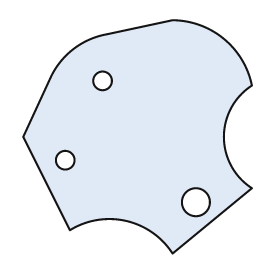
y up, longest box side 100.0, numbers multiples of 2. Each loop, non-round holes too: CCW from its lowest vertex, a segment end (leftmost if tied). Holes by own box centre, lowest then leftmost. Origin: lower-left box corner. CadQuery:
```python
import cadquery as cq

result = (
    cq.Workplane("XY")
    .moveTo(64.0, 0.0)
    .lineTo(98.0, 28.0)
    .threePointArc((86.0, 50.0), (98.0, 72.0))
    .threePointArc((86.0, 92.0), (64.0, 100.0))
    .lineTo(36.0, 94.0)
    .threePointArc((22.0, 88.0), (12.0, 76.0))
    .lineTo(0.0, 50.0)
    .lineTo(20.0, 10.0)
    .threePointArc((44.0, 14.0), (64.0, 0.0))
    .close()
    .moveTo(74.0, 22.0)
    .circle(6.0)
    .moveTo(18.0, 40.0)
    .circle(4.0)
    .moveTo(34.0, 74.0)
    .circle(4.0)
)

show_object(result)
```